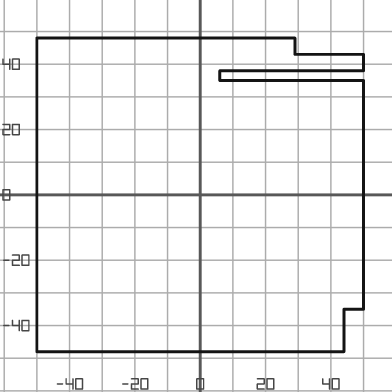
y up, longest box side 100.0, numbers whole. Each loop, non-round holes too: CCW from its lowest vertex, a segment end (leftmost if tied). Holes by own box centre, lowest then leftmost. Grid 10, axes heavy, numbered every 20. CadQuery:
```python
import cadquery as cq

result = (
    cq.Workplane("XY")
    .moveTo(-50.0, -48.0)
    .lineTo(44.0, -48.0)
    .lineTo(44.0, -35.0)
    .lineTo(50.0, -35.0)
    .lineTo(50.0, 35.0)
    .lineTo(6.0, 35.0)
    .lineTo(6.0, 38.0)
    .lineTo(50.0, 38.0)
    .lineTo(50.0, 43.0)
    .lineTo(29.0, 43.0)
    .lineTo(29.0, 48.0)
    .lineTo(-50.0, 48.0)
    .close()
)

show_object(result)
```